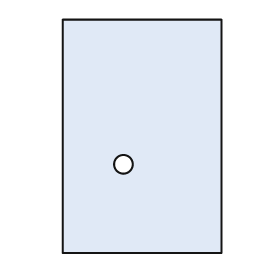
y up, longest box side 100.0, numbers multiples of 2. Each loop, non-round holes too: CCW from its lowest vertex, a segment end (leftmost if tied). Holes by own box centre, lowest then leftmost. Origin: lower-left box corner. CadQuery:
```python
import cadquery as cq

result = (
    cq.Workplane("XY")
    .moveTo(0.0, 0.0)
    .lineTo(68.0, 0.0)
    .lineTo(68.0, 100.0)
    .lineTo(0.0, 100.0)
    .close()
    .moveTo(26.0, 38.0)
    .circle(4.0)
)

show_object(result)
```